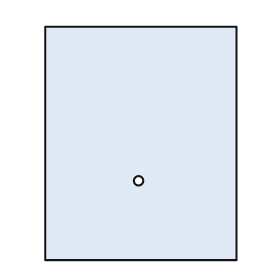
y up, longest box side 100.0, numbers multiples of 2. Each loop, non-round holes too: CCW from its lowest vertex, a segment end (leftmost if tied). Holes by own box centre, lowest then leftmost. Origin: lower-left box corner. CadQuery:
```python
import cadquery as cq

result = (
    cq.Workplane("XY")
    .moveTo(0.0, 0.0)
    .lineTo(82.0, 0.0)
    .lineTo(82.0, 100.0)
    .lineTo(0.0, 100.0)
    .close()
    .moveTo(40.0, 34.0)
    .circle(2.0)
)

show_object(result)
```